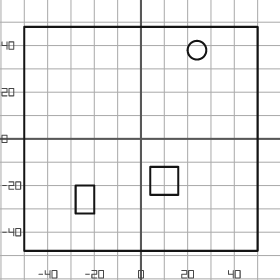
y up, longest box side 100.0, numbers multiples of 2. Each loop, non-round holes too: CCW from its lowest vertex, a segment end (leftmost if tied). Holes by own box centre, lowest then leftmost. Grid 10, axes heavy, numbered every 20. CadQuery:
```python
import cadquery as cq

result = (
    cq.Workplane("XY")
    .moveTo(-50.0, -48.0)
    .lineTo(50.0, -48.0)
    .lineTo(50.0, 48.0)
    .lineTo(-50.0, 48.0)
    .close()
    .moveTo(-28.0, -32.0)
    .lineTo(-20.0, -32.0)
    .lineTo(-20.0, -20.0)
    .lineTo(-28.0, -20.0)
    .close()
    .moveTo(4.0, -24.0)
    .lineTo(16.0, -24.0)
    .lineTo(16.0, -12.0)
    .lineTo(4.0, -12.0)
    .close()
    .moveTo(24.0, 38.0)
    .circle(4.0)
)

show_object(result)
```